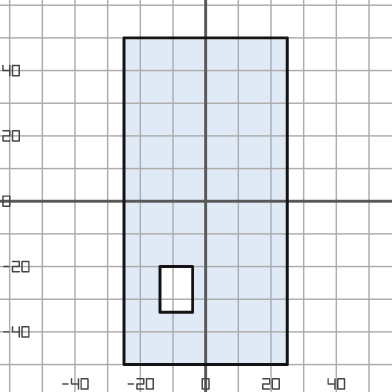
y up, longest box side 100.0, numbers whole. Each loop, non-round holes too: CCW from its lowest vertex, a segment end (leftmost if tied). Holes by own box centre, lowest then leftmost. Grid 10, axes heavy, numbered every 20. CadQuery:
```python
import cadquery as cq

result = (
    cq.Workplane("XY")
    .moveTo(-25.0, -50.0)
    .lineTo(25.0, -50.0)
    .lineTo(25.0, 50.0)
    .lineTo(-25.0, 50.0)
    .close()
    .moveTo(-14.0, -34.0)
    .lineTo(-4.0, -34.0)
    .lineTo(-4.0, -20.0)
    .lineTo(-14.0, -20.0)
    .close()
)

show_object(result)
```